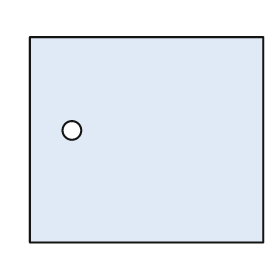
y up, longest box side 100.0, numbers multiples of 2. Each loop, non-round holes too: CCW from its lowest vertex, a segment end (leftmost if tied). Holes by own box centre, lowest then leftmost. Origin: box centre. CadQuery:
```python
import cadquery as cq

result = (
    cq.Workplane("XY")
    .moveTo(-50.0, -44.0)
    .lineTo(50.0, -44.0)
    .lineTo(50.0, 44.0)
    .lineTo(-50.0, 44.0)
    .close()
    .moveTo(-32.0, 4.0)
    .circle(4.0)
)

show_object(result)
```